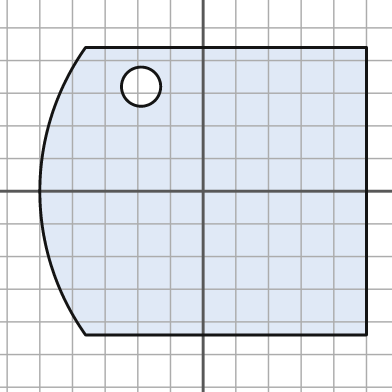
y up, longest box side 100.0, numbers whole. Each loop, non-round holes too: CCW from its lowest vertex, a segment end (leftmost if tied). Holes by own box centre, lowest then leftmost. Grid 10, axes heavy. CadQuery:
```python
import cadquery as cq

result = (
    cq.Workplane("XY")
    .moveTo(-36.0, -44.0)
    .lineTo(50.0, -44.0)
    .lineTo(50.0, 44.0)
    .lineTo(-36.0, 44.0)
    .threePointArc((-50.0, 0.0), (-36.0, -44.0))
    .close()
    .moveTo(-19.0, 32.0)
    .circle(6.0)
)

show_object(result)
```